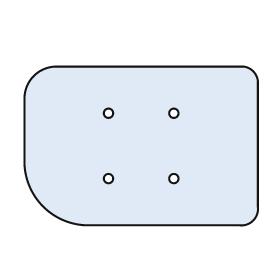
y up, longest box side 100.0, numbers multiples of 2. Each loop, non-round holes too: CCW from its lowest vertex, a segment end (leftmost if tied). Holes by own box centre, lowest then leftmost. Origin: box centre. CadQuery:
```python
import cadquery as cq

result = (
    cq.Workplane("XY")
    .moveTo(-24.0, -34.0)
    .lineTo(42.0, -34.0)
    .threePointArc((48.0, -32.0), (50.0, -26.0))
    .lineTo(50.0, 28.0)
    .threePointArc((48.0, 32.0), (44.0, 34.0))
    .lineTo(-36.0, 34.0)
    .threePointArc((-46.0, 30.0), (-50.0, 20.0))
    .lineTo(-50.0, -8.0)
    .threePointArc((-42.0, -26.0), (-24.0, -34.0))
    .close()
    .moveTo(-14.0, -14.0)
    .circle(2.0)
    .moveTo(14.0, -14.0)
    .circle(2.0)
    .moveTo(-14.0, 14.0)
    .circle(2.0)
    .moveTo(14.0, 14.0)
    .circle(2.0)
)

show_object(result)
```